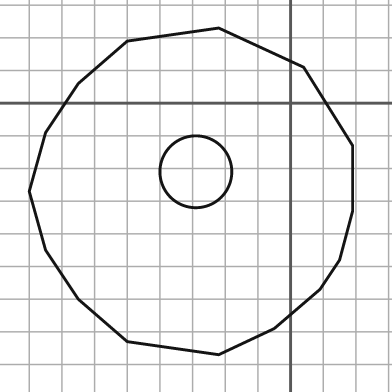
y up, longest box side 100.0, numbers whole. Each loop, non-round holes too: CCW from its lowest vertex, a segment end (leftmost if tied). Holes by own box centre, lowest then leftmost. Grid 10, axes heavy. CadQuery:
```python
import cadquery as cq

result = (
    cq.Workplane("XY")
    .moveTo(-22.0, -77.0)
    .lineTo(-5.0, -69.0)
    .lineTo(9.0, -57.0)
    .lineTo(15.0, -48.0)
    .lineTo(19.0, -33.0)
    .lineTo(19.0, -13.0)
    .lineTo(4.0, 11.0)
    .lineTo(-22.0, 23.0)
    .lineTo(-50.0, 19.0)
    .lineTo(-65.0, 6.0)
    .lineTo(-75.0, -9.0)
    .lineTo(-80.0, -27.0)
    .lineTo(-75.0, -45.0)
    .lineTo(-65.0, -60.0)
    .lineTo(-50.0, -73.0)
    .close()
    .moveTo(-29.0, -21.0)
    .circle(11.0)
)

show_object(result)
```